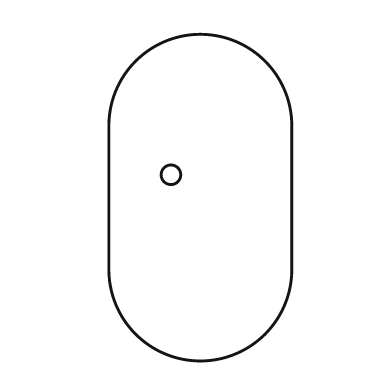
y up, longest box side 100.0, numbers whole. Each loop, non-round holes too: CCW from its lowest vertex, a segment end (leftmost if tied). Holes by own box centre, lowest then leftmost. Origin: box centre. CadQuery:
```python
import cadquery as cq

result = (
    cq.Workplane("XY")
    .moveTo(-28.0, -22.0)
    .threePointArc((0.0, -50.0), (28.0, -22.0))
    .lineTo(28.0, 22.0)
    .threePointArc((0.0, 50.0), (-28.0, 22.0))
    .close()
    .moveTo(-9.0, 7.0)
    .circle(3.0)
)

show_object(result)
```